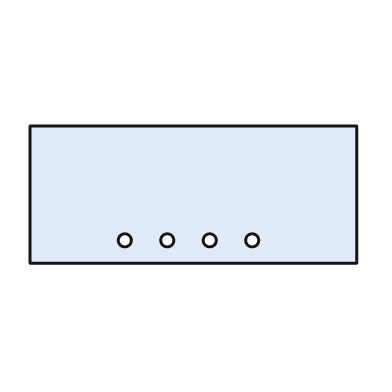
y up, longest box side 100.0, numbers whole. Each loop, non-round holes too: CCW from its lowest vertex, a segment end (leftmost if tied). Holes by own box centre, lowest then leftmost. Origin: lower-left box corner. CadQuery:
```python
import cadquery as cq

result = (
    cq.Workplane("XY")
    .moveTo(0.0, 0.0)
    .lineTo(100.0, 0.0)
    .lineTo(100.0, 42.0)
    .lineTo(0.0, 42.0)
    .close()
    .moveTo(29.0, 7.0)
    .circle(2.0)
    .moveTo(42.0, 7.0)
    .circle(2.0)
    .moveTo(55.0, 7.0)
    .circle(2.0)
    .moveTo(68.0, 7.0)
    .circle(2.0)
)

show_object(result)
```